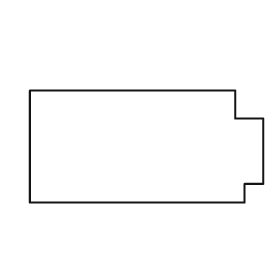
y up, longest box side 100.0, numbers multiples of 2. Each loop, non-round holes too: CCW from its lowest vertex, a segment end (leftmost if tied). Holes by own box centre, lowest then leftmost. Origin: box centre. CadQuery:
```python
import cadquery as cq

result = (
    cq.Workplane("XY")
    .moveTo(-50.0, -24.0)
    .lineTo(42.0, -24.0)
    .lineTo(42.0, -16.0)
    .lineTo(50.0, -16.0)
    .lineTo(50.0, 12.0)
    .lineTo(38.0, 12.0)
    .lineTo(38.0, 24.0)
    .lineTo(-50.0, 24.0)
    .close()
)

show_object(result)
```